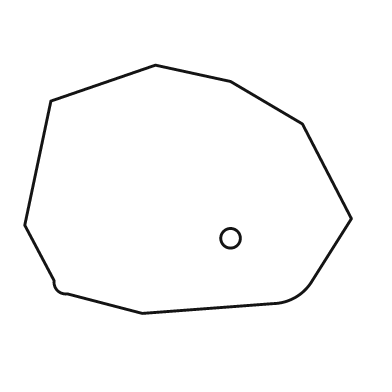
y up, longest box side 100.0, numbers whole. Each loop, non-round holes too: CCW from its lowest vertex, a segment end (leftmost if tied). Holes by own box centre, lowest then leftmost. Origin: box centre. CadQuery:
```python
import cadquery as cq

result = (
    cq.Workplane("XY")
    .moveTo(-14.0, -38.0)
    .lineTo(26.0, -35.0)
    .threePointArc((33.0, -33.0), (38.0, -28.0))
    .lineTo(50.0, -9.0)
    .lineTo(35.0, 20.0)
    .lineTo(13.0, 33.0)
    .lineTo(-10.0, 38.0)
    .lineTo(-42.0, 27.0)
    .lineTo(-50.0, -11.0)
    .lineTo(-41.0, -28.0)
    .threePointArc((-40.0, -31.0), (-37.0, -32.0))
    .close()
    .moveTo(13.0, -15.0)
    .circle(3.0)
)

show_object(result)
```